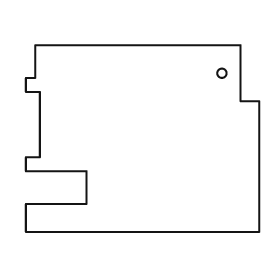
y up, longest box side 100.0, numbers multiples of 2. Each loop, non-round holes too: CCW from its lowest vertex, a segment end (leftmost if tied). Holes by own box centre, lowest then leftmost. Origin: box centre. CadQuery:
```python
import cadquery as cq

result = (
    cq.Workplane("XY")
    .moveTo(-50.0, -40.0)
    .lineTo(50.0, -40.0)
    .lineTo(50.0, 16.0)
    .lineTo(42.0, 16.0)
    .lineTo(42.0, 40.0)
    .lineTo(-46.0, 40.0)
    .lineTo(-46.0, 26.0)
    .lineTo(-50.0, 26.0)
    .lineTo(-50.0, 20.0)
    .lineTo(-44.0, 20.0)
    .lineTo(-44.0, -8.0)
    .lineTo(-50.0, -8.0)
    .lineTo(-50.0, -14.0)
    .lineTo(-24.0, -14.0)
    .lineTo(-24.0, -28.0)
    .lineTo(-50.0, -28.0)
    .close()
    .moveTo(34.0, 28.0)
    .circle(2.0)
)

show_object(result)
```